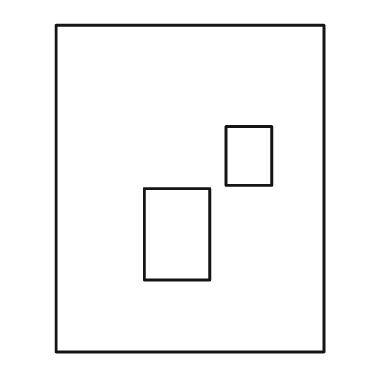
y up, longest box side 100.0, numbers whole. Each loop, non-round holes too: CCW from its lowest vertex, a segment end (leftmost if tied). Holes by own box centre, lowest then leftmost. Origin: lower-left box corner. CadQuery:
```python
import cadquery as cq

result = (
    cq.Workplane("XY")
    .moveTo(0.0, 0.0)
    .lineTo(82.0, 0.0)
    .lineTo(82.0, 100.0)
    .lineTo(0.0, 100.0)
    .close()
    .moveTo(27.0, 22.0)
    .lineTo(47.0, 22.0)
    .lineTo(47.0, 50.0)
    .lineTo(27.0, 50.0)
    .close()
    .moveTo(52.0, 51.0)
    .lineTo(66.0, 51.0)
    .lineTo(66.0, 69.0)
    .lineTo(52.0, 69.0)
    .close()
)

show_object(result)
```